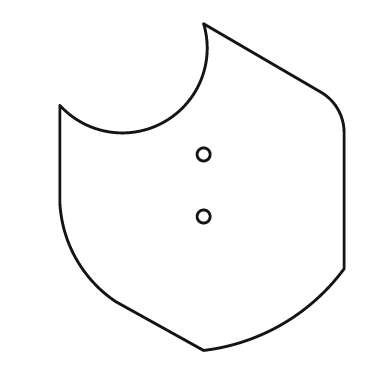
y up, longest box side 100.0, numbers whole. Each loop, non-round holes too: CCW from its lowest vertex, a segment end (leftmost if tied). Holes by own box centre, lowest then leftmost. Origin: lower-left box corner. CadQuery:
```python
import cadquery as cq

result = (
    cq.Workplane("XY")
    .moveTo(44.0, 0.0)
    .threePointArc((68.0, 8.0), (87.0, 25.0))
    .lineTo(87.0, 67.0)
    .threePointArc((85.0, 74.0), (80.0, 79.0))
    .lineTo(44.0, 100.0)
    .threePointArc((32.0, 70.0), (0.0, 75.0))
    .lineTo(0.0, 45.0)
    .threePointArc((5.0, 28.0), (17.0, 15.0))
    .close()
    .moveTo(44.0, 41.0)
    .circle(2.0)
    .moveTo(44.0, 60.0)
    .circle(2.0)
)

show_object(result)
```